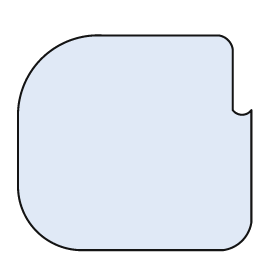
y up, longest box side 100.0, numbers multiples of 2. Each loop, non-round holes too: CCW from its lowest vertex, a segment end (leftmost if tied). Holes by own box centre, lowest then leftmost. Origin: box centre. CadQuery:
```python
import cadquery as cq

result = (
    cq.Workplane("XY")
    .moveTo(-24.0, -46.0)
    .lineTo(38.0, -46.0)
    .threePointArc((46.0, -42.0), (50.0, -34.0))
    .lineTo(50.0, 14.0)
    .threePointArc((46.0, 12.0), (42.0, 14.0))
    .lineTo(42.0, 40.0)
    .threePointArc((40.0, 44.0), (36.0, 46.0))
    .lineTo(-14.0, 46.0)
    .threePointArc((-40.0, 36.0), (-50.0, 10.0))
    .lineTo(-50.0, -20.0)
    .threePointArc((-42.0, -38.0), (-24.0, -46.0))
    .close()
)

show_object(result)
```